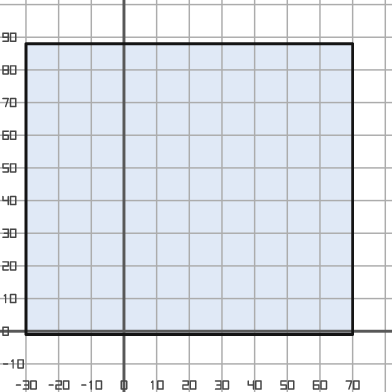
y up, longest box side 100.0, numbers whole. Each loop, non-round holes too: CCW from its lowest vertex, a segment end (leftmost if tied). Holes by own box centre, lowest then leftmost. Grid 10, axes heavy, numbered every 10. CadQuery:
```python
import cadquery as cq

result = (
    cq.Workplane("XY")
    .moveTo(-30.0, -1.0)
    .lineTo(70.0, -1.0)
    .lineTo(70.0, 88.0)
    .lineTo(-30.0, 88.0)
    .close()
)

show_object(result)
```